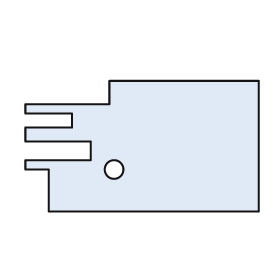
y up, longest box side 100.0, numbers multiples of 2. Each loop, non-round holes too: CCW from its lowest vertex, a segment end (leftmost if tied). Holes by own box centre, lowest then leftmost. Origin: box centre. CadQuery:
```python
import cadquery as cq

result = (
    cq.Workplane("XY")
    .moveTo(-40.0, -28.0)
    .lineTo(50.0, -28.0)
    .lineTo(50.0, 28.0)
    .lineTo(-14.0, 28.0)
    .lineTo(-14.0, 18.0)
    .lineTo(-50.0, 18.0)
    .lineTo(-50.0, 14.0)
    .lineTo(-30.0, 14.0)
    .lineTo(-30.0, 8.0)
    .lineTo(-50.0, 8.0)
    .lineTo(-50.0, 2.0)
    .lineTo(-22.0, 2.0)
    .lineTo(-22.0, -6.0)
    .lineTo(-50.0, -6.0)
    .lineTo(-50.0, -10.0)
    .lineTo(-40.0, -10.0)
    .close()
    .moveTo(-12.0, -10.0)
    .circle(4.0)
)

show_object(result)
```